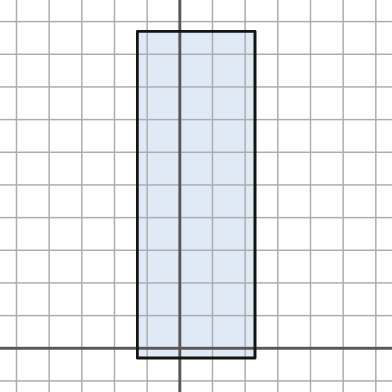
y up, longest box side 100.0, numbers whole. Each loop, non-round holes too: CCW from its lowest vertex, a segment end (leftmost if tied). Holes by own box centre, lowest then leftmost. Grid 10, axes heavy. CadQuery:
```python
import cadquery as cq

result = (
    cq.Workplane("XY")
    .moveTo(-13.0, -3.0)
    .lineTo(23.0, -3.0)
    .lineTo(23.0, 97.0)
    .lineTo(-13.0, 97.0)
    .close()
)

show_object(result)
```